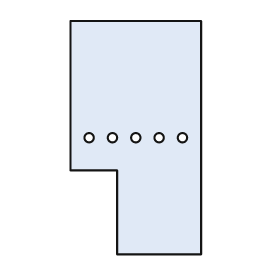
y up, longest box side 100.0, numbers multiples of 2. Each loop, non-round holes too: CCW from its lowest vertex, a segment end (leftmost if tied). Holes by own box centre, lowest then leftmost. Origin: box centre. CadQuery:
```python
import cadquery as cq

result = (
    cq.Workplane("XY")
    .moveTo(-8.0, -50.0)
    .lineTo(28.0, -50.0)
    .lineTo(28.0, 50.0)
    .lineTo(-28.0, 50.0)
    .lineTo(-28.0, -14.0)
    .lineTo(-8.0, -14.0)
    .close()
    .moveTo(-20.0, 0.0)
    .circle(2.0)
    .moveTo(-10.0, 0.0)
    .circle(2.0)
    .moveTo(0.0, 0.0)
    .circle(2.0)
    .moveTo(10.0, 0.0)
    .circle(2.0)
    .moveTo(20.0, 0.0)
    .circle(2.0)
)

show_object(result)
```